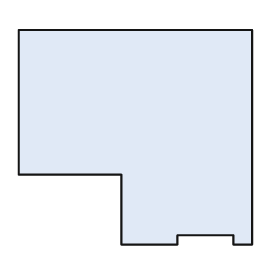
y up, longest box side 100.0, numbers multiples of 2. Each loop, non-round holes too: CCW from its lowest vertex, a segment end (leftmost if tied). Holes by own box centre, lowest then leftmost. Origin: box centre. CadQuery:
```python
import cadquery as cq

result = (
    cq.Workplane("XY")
    .moveTo(-6.0, -46.0)
    .lineTo(18.0, -46.0)
    .lineTo(18.0, -42.0)
    .lineTo(42.0, -42.0)
    .lineTo(42.0, -46.0)
    .lineTo(50.0, -46.0)
    .lineTo(50.0, 46.0)
    .lineTo(-50.0, 46.0)
    .lineTo(-50.0, -16.0)
    .lineTo(-6.0, -16.0)
    .close()
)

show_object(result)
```